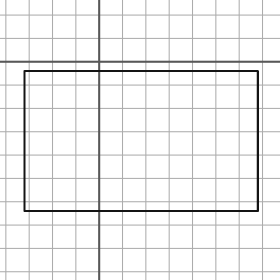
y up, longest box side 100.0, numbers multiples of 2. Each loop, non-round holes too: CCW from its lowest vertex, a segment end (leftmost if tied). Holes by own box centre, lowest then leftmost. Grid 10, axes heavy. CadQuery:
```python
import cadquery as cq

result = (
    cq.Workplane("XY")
    .moveTo(-32.0, -64.0)
    .lineTo(68.0, -64.0)
    .lineTo(68.0, -4.0)
    .lineTo(-32.0, -4.0)
    .close()
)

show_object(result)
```